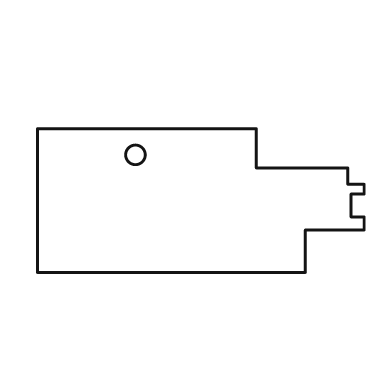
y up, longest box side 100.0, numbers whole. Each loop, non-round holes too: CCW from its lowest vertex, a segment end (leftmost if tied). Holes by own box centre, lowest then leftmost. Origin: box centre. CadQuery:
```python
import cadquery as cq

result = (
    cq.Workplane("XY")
    .moveTo(-50.0, -22.0)
    .lineTo(32.0, -22.0)
    .lineTo(32.0, -9.0)
    .lineTo(50.0, -9.0)
    .lineTo(50.0, -5.0)
    .lineTo(46.0, -5.0)
    .lineTo(46.0, 2.0)
    .lineTo(50.0, 2.0)
    .lineTo(50.0, 5.0)
    .lineTo(45.0, 5.0)
    .lineTo(45.0, 10.0)
    .lineTo(17.0, 10.0)
    .lineTo(17.0, 22.0)
    .lineTo(-50.0, 22.0)
    .close()
    .moveTo(-20.0, 14.0)
    .circle(3.0)
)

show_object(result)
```